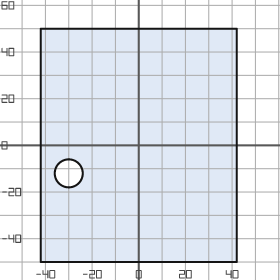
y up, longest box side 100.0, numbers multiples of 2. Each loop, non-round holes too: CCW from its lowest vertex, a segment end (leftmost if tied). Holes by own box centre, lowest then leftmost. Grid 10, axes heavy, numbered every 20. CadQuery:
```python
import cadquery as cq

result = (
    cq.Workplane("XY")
    .moveTo(-42.0, -50.0)
    .lineTo(42.0, -50.0)
    .lineTo(42.0, 50.0)
    .lineTo(-42.0, 50.0)
    .close()
    .moveTo(-30.0, -12.0)
    .circle(6.0)
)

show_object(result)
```